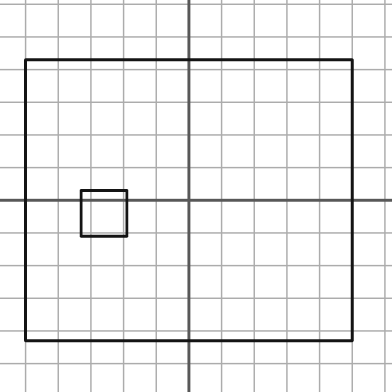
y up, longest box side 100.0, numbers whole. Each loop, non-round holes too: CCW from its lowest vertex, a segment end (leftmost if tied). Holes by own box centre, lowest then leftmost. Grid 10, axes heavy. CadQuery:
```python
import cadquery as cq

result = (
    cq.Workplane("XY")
    .moveTo(-50.0, -43.0)
    .lineTo(50.0, -43.0)
    .lineTo(50.0, 43.0)
    .lineTo(-50.0, 43.0)
    .close()
    .moveTo(-33.0, -11.0)
    .lineTo(-19.0, -11.0)
    .lineTo(-19.0, 3.0)
    .lineTo(-33.0, 3.0)
    .close()
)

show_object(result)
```